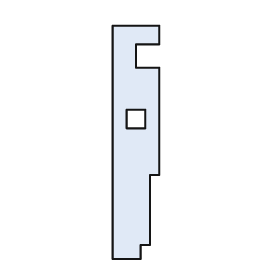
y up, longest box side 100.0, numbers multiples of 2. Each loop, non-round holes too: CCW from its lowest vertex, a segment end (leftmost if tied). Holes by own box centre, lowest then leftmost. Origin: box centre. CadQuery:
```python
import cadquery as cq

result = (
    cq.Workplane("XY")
    .moveTo(-10.0, -50.0)
    .lineTo(2.0, -50.0)
    .lineTo(2.0, -44.0)
    .lineTo(6.0, -44.0)
    .lineTo(6.0, -14.0)
    .lineTo(10.0, -14.0)
    .lineTo(10.0, 32.0)
    .lineTo(0.0, 32.0)
    .lineTo(0.0, 42.0)
    .lineTo(10.0, 42.0)
    .lineTo(10.0, 50.0)
    .lineTo(-10.0, 50.0)
    .close()
    .moveTo(-4.0, 6.0)
    .lineTo(4.0, 6.0)
    .lineTo(4.0, 14.0)
    .lineTo(-4.0, 14.0)
    .close()
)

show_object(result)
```